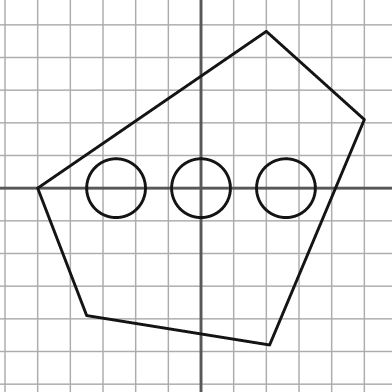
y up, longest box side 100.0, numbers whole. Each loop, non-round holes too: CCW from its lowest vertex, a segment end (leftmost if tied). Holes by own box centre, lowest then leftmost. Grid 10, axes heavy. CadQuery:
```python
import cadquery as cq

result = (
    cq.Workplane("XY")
    .moveTo(21.0, -48.0)
    .lineTo(50.0, 21.0)
    .lineTo(20.0, 48.0)
    .lineTo(-50.0, 0.0)
    .lineTo(-35.0, -39.0)
    .close()
    .moveTo(-26.0, 0.0)
    .circle(9.0)
    .moveTo(0.0, 0.0)
    .circle(9.0)
    .moveTo(26.0, 0.0)
    .circle(9.0)
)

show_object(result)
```